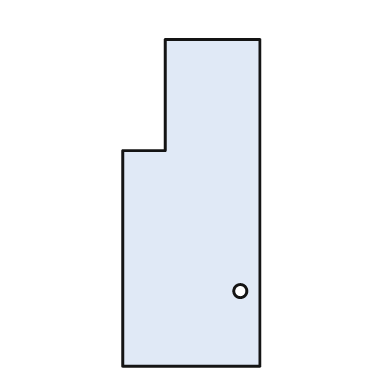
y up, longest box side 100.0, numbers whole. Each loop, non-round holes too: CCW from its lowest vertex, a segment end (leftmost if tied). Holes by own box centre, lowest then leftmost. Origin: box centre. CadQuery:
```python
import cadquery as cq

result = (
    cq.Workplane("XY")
    .moveTo(-21.0, -50.0)
    .lineTo(21.0, -50.0)
    .lineTo(21.0, 50.0)
    .lineTo(-8.0, 50.0)
    .lineTo(-8.0, 16.0)
    .lineTo(-21.0, 16.0)
    .close()
    .moveTo(15.0, -27.0)
    .circle(2.0)
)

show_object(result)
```